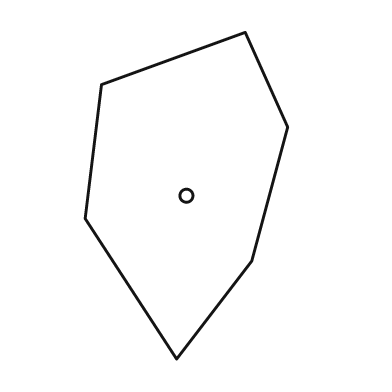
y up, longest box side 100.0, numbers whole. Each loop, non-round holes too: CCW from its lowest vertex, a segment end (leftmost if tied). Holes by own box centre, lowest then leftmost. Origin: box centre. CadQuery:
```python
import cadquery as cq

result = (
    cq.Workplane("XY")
    .moveTo(-3.0, -50.0)
    .lineTo(20.0, -20.0)
    .lineTo(31.0, 21.0)
    .lineTo(18.0, 50.0)
    .lineTo(-26.0, 34.0)
    .lineTo(-31.0, -7.0)
    .close()
    .moveTo(0.0, 0.0)
    .circle(2.0)
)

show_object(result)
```